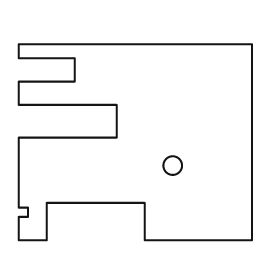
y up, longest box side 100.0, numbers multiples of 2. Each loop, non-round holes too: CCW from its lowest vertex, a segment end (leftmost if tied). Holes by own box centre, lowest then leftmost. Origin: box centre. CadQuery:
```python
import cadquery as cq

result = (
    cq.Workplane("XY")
    .moveTo(-50.0, -42.0)
    .lineTo(-38.0, -42.0)
    .lineTo(-38.0, -26.0)
    .lineTo(4.0, -26.0)
    .lineTo(4.0, -42.0)
    .lineTo(50.0, -42.0)
    .lineTo(50.0, 42.0)
    .lineTo(-50.0, 42.0)
    .lineTo(-50.0, 36.0)
    .lineTo(-26.0, 36.0)
    .lineTo(-26.0, 26.0)
    .lineTo(-50.0, 26.0)
    .lineTo(-50.0, 16.0)
    .lineTo(-8.0, 16.0)
    .lineTo(-8.0, 2.0)
    .lineTo(-50.0, 2.0)
    .lineTo(-50.0, -28.0)
    .lineTo(-46.0, -28.0)
    .lineTo(-46.0, -32.0)
    .lineTo(-50.0, -32.0)
    .close()
    .moveTo(16.0, -10.0)
    .circle(4.0)
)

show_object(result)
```